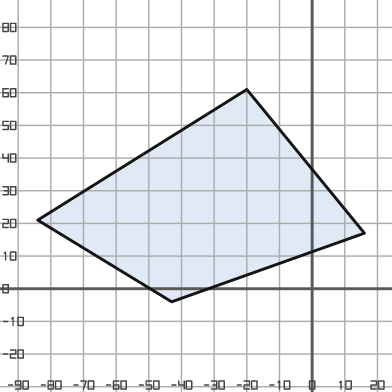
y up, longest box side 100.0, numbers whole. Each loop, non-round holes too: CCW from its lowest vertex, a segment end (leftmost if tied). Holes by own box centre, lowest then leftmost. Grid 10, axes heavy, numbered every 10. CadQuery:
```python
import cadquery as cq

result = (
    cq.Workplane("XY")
    .moveTo(-43.0, -4.0)
    .lineTo(16.0, 17.0)
    .lineTo(-20.0, 61.0)
    .lineTo(-84.0, 21.0)
    .close()
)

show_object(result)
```